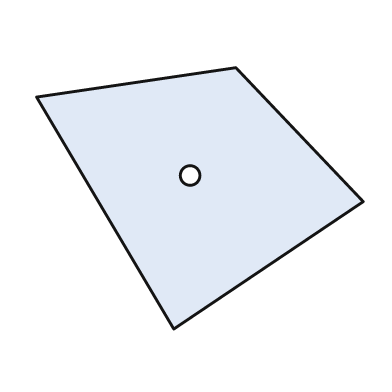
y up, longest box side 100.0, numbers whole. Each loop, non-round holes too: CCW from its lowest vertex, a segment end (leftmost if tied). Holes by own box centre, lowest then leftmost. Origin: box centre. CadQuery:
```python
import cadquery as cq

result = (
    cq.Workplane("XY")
    .moveTo(-8.0, -40.0)
    .lineTo(50.0, -1.0)
    .lineTo(11.0, 40.0)
    .lineTo(-50.0, 31.0)
    .close()
    .moveTo(-3.0, 7.0)
    .circle(3.0)
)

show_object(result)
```